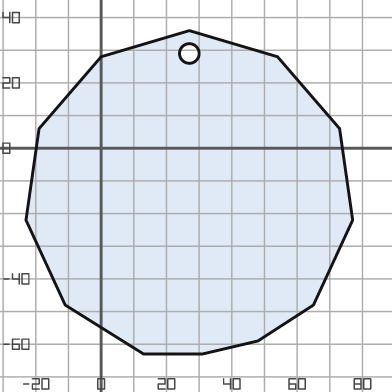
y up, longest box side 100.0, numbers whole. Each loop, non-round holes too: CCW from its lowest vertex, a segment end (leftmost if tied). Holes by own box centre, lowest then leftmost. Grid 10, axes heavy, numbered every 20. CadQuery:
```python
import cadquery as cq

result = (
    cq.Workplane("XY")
    .moveTo(13.0, -63.0)
    .lineTo(31.0, -63.0)
    .lineTo(48.0, -59.0)
    .lineTo(65.0, -48.0)
    .lineTo(77.0, -22.0)
    .lineTo(73.0, 6.0)
    .lineTo(54.0, 28.0)
    .lineTo(27.0, 36.0)
    .lineTo(0.0, 28.0)
    .lineTo(-19.0, 6.0)
    .lineTo(-23.0, -22.0)
    .lineTo(-11.0, -48.0)
    .close()
    .moveTo(27.0, 29.0)
    .circle(3.0)
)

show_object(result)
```